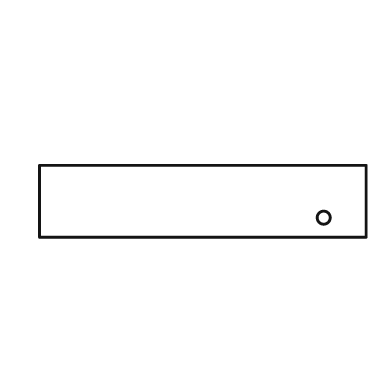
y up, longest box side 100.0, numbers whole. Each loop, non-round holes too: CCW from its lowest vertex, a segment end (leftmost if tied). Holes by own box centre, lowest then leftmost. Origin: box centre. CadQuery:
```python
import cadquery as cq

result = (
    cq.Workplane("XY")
    .moveTo(-50.0, -11.0)
    .lineTo(50.0, -11.0)
    .lineTo(50.0, 11.0)
    .lineTo(-50.0, 11.0)
    .close()
    .moveTo(37.0, -5.0)
    .circle(2.0)
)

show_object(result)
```